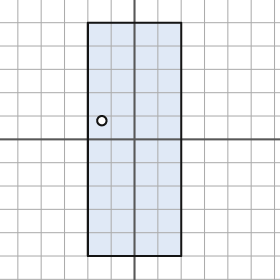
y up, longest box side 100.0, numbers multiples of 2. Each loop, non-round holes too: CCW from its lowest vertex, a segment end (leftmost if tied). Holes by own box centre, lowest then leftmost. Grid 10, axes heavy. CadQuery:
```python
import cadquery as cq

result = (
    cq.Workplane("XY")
    .moveTo(-20.0, -50.0)
    .lineTo(20.0, -50.0)
    .lineTo(20.0, 50.0)
    .lineTo(-20.0, 50.0)
    .close()
    .moveTo(-14.0, 8.0)
    .circle(2.0)
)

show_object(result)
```